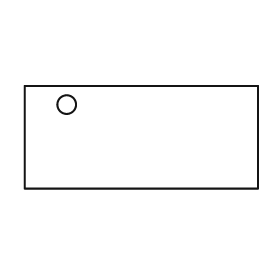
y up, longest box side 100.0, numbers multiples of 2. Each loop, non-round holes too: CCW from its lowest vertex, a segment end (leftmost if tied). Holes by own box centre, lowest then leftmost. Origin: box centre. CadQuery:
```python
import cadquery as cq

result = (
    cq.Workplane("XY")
    .moveTo(-50.0, -22.0)
    .lineTo(50.0, -22.0)
    .lineTo(50.0, 22.0)
    .lineTo(-50.0, 22.0)
    .close()
    .moveTo(-32.0, 14.0)
    .circle(4.0)
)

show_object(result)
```